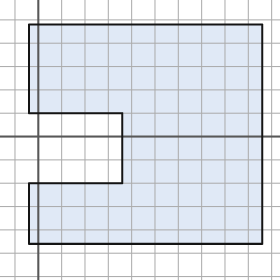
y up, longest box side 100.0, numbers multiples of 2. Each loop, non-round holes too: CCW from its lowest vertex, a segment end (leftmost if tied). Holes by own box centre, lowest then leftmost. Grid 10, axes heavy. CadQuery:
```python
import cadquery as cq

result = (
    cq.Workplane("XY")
    .moveTo(-4.0, -46.0)
    .lineTo(96.0, -46.0)
    .lineTo(96.0, 48.0)
    .lineTo(-4.0, 48.0)
    .lineTo(-4.0, 10.0)
    .lineTo(36.0, 10.0)
    .lineTo(36.0, -20.0)
    .lineTo(-4.0, -20.0)
    .close()
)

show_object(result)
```